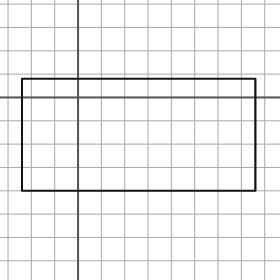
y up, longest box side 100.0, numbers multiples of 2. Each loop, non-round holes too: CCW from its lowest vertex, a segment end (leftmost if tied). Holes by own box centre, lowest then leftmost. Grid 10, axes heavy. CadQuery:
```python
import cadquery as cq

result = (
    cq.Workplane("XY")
    .moveTo(-24.0, -40.0)
    .lineTo(76.0, -40.0)
    .lineTo(76.0, 8.0)
    .lineTo(-24.0, 8.0)
    .close()
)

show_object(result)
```